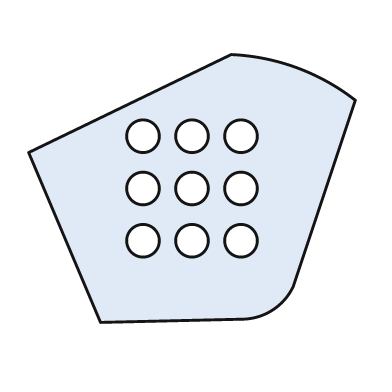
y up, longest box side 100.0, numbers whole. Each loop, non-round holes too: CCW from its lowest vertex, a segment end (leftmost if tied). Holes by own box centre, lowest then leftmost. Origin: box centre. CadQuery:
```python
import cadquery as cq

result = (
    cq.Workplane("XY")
    .moveTo(-28.0, -41.0)
    .lineTo(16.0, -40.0)
    .threePointArc((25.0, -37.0), (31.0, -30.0))
    .lineTo(50.0, 27.0)
    .threePointArc((32.0, 37.0), (12.0, 41.0))
    .lineTo(-50.0, 11.0)
    .close()
    .moveTo(-15.0, -16.0)
    .circle(5.0)
    .moveTo(0.0, -16.0)
    .circle(5.0)
    .moveTo(15.0, -16.0)
    .circle(5.0)
    .moveTo(-15.0, 0.0)
    .circle(5.0)
    .moveTo(0.0, 0.0)
    .circle(5.0)
    .moveTo(15.0, 0.0)
    .circle(5.0)
    .moveTo(-15.0, 16.0)
    .circle(5.0)
    .moveTo(0.0, 16.0)
    .circle(5.0)
    .moveTo(15.0, 16.0)
    .circle(5.0)
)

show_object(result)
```